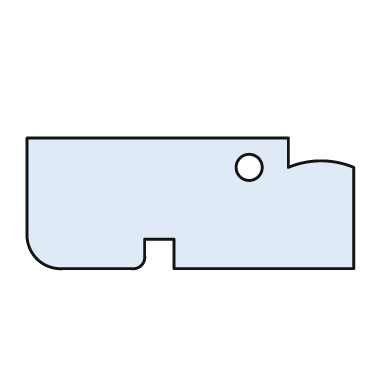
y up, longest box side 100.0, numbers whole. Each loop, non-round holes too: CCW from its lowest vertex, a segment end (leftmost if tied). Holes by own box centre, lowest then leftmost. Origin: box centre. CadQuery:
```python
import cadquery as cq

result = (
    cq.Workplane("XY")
    .moveTo(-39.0, -20.0)
    .lineTo(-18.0, -20.0)
    .threePointArc((-15.0, -19.0), (-14.0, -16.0))
    .lineTo(-14.0, -11.0)
    .lineTo(-5.0, -11.0)
    .lineTo(-5.0, -20.0)
    .lineTo(50.0, -20.0)
    .lineTo(50.0, 11.0)
    .threePointArc((40.0, 13.0), (30.0, 11.0))
    .lineTo(30.0, 20.0)
    .lineTo(-50.0, 20.0)
    .lineTo(-50.0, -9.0)
    .threePointArc((-47.0, -17.0), (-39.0, -20.0))
    .close()
    .moveTo(18.0, 11.0)
    .circle(4.0)
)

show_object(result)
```